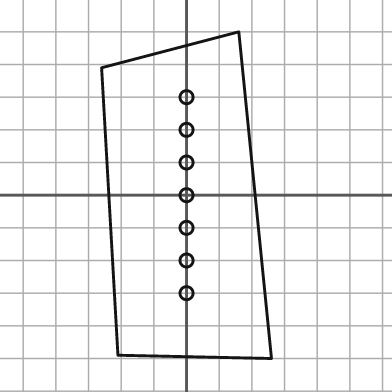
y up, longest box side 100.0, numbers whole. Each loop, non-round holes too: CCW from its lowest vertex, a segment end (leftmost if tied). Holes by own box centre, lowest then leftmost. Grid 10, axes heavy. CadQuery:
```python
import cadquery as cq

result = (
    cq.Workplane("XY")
    .moveTo(26.0, -50.0)
    .lineTo(16.0, 50.0)
    .lineTo(-26.0, 39.0)
    .lineTo(-21.0, -49.0)
    .close()
    .moveTo(0.0, -30.0)
    .circle(2.0)
    .moveTo(0.0, -20.0)
    .circle(2.0)
    .moveTo(0.0, -10.0)
    .circle(2.0)
    .moveTo(0.0, 0.0)
    .circle(2.0)
    .moveTo(0.0, 10.0)
    .circle(2.0)
    .moveTo(0.0, 20.0)
    .circle(2.0)
    .moveTo(0.0, 30.0)
    .circle(2.0)
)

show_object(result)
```